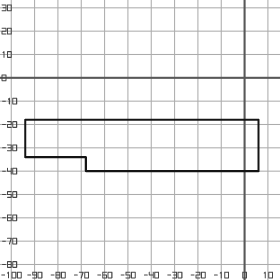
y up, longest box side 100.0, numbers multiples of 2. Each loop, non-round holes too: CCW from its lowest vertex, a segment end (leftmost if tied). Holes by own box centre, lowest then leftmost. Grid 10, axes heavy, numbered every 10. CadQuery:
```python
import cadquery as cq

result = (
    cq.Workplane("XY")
    .moveTo(-68.0, -40.0)
    .lineTo(6.0, -40.0)
    .lineTo(6.0, -18.0)
    .lineTo(-94.0, -18.0)
    .lineTo(-94.0, -34.0)
    .lineTo(-68.0, -34.0)
    .close()
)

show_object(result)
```